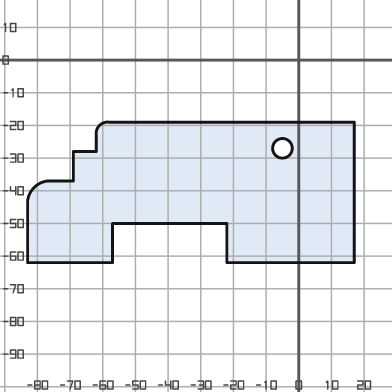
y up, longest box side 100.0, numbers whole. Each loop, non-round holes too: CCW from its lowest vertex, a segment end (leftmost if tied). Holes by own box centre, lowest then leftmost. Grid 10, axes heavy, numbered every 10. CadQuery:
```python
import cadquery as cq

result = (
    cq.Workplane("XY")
    .moveTo(-83.0, -62.0)
    .lineTo(-57.0, -62.0)
    .lineTo(-57.0, -50.0)
    .lineTo(-22.0, -50.0)
    .lineTo(-22.0, -62.0)
    .lineTo(17.0, -62.0)
    .lineTo(17.0, -19.0)
    .lineTo(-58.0, -19.0)
    .threePointArc((-61.0, -20.0), (-62.0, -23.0))
    .lineTo(-62.0, -28.0)
    .lineTo(-69.0, -28.0)
    .lineTo(-69.0, -37.0)
    .lineTo(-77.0, -37.0)
    .threePointArc((-81.0, -39.0), (-83.0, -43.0))
    .close()
    .moveTo(-5.0, -27.0)
    .circle(3.0)
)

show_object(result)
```